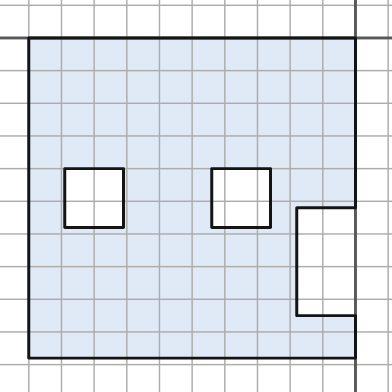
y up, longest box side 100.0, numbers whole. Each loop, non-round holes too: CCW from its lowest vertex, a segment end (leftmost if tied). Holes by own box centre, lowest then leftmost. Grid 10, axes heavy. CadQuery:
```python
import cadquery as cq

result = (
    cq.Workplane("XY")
    .moveTo(-100.0, -98.0)
    .lineTo(0.0, -98.0)
    .lineTo(0.0, -85.0)
    .lineTo(-18.0, -85.0)
    .lineTo(-18.0, -52.0)
    .lineTo(0.0, -52.0)
    .lineTo(0.0, 0.0)
    .lineTo(-100.0, 0.0)
    .close()
    .moveTo(-89.0, -58.0)
    .lineTo(-71.0, -58.0)
    .lineTo(-71.0, -40.0)
    .lineTo(-89.0, -40.0)
    .close()
    .moveTo(-44.0, -58.0)
    .lineTo(-26.0, -58.0)
    .lineTo(-26.0, -40.0)
    .lineTo(-44.0, -40.0)
    .close()
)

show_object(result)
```